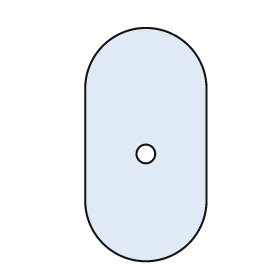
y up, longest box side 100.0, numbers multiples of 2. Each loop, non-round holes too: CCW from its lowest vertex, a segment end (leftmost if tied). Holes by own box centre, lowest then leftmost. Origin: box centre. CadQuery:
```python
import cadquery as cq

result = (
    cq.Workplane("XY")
    .moveTo(-26.0, -24.0)
    .threePointArc((0.0, -50.0), (26.0, -24.0))
    .lineTo(26.0, 24.0)
    .threePointArc((0.0, 50.0), (-26.0, 24.0))
    .close()
    .moveTo(0.0, -4.0)
    .circle(4.0)
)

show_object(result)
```